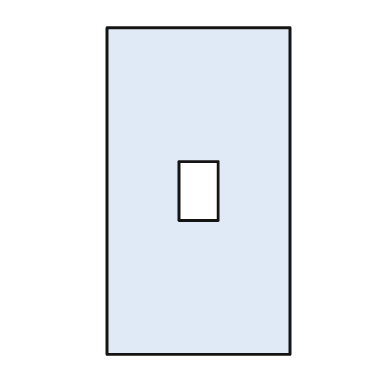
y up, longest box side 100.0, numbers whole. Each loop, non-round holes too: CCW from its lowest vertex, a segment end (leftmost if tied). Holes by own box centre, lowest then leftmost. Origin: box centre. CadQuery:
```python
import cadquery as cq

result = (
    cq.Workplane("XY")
    .moveTo(-28.0, -50.0)
    .lineTo(28.0, -50.0)
    .lineTo(28.0, 50.0)
    .lineTo(-28.0, 50.0)
    .close()
    .moveTo(-6.0, -9.0)
    .lineTo(6.0, -9.0)
    .lineTo(6.0, 9.0)
    .lineTo(-6.0, 9.0)
    .close()
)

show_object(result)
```